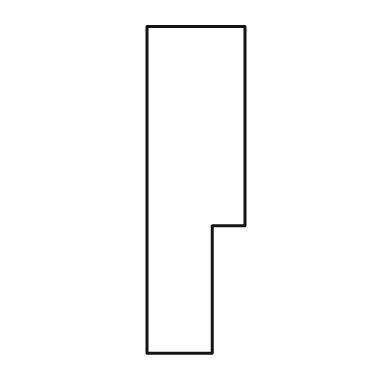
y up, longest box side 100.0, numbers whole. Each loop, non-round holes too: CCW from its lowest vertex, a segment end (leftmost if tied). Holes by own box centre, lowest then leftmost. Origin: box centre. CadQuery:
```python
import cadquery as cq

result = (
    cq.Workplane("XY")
    .moveTo(-15.0, -50.0)
    .lineTo(5.0, -50.0)
    .lineTo(5.0, -11.0)
    .lineTo(15.0, -11.0)
    .lineTo(15.0, 50.0)
    .lineTo(-15.0, 50.0)
    .close()
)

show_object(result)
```